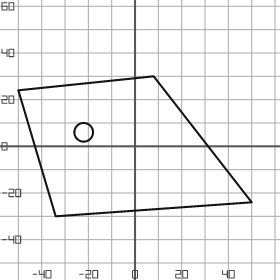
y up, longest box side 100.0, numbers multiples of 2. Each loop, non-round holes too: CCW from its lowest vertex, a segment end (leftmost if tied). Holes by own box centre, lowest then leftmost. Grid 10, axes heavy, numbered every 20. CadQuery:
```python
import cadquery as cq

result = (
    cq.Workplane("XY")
    .moveTo(-34.0, -30.0)
    .lineTo(50.0, -24.0)
    .lineTo(8.0, 30.0)
    .lineTo(-50.0, 24.0)
    .close()
    .moveTo(-22.0, 6.0)
    .circle(4.0)
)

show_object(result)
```